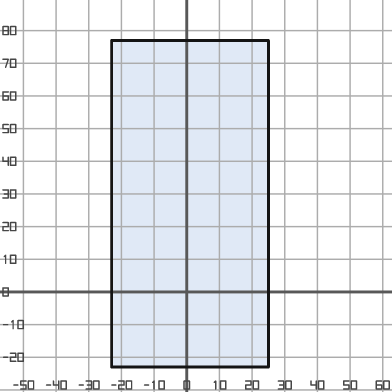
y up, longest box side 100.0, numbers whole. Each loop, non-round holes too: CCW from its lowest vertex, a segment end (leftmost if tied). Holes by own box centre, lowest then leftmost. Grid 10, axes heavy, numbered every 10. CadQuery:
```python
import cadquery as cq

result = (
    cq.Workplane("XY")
    .moveTo(-23.0, -23.0)
    .lineTo(25.0, -23.0)
    .lineTo(25.0, 77.0)
    .lineTo(-23.0, 77.0)
    .close()
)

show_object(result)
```